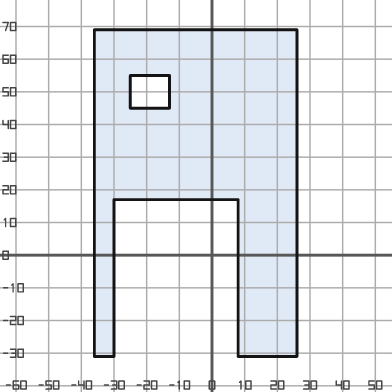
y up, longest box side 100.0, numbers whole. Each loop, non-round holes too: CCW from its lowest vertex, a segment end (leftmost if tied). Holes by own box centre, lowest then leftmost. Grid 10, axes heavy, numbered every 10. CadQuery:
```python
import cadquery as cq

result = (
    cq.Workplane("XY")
    .moveTo(-36.0, -31.0)
    .lineTo(-30.0, -31.0)
    .lineTo(-30.0, 17.0)
    .lineTo(8.0, 17.0)
    .lineTo(8.0, -31.0)
    .lineTo(26.0, -31.0)
    .lineTo(26.0, 69.0)
    .lineTo(-36.0, 69.0)
    .close()
    .moveTo(-25.0, 45.0)
    .lineTo(-13.0, 45.0)
    .lineTo(-13.0, 55.0)
    .lineTo(-25.0, 55.0)
    .close()
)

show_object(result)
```